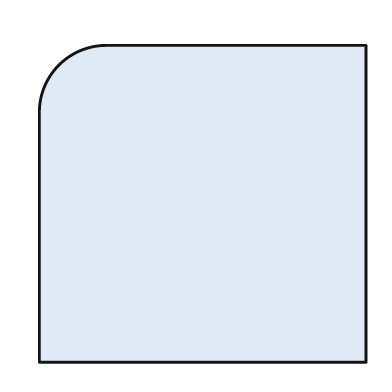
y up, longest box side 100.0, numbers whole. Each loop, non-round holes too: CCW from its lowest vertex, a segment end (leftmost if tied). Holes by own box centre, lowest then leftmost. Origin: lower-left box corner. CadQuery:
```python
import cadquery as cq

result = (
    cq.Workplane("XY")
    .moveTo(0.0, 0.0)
    .lineTo(100.0, 0.0)
    .lineTo(100.0, 97.0)
    .lineTo(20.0, 97.0)
    .threePointArc((6.0, 91.0), (0.0, 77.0))
    .close()
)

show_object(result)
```